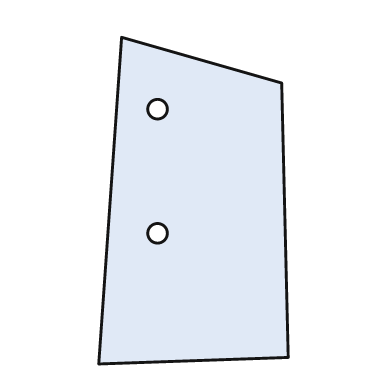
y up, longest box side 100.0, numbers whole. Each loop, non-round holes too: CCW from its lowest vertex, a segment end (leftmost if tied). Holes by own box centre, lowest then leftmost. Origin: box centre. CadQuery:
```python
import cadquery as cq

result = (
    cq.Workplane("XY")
    .moveTo(-29.0, -50.0)
    .lineTo(29.0, -48.0)
    .lineTo(27.0, 36.0)
    .lineTo(-22.0, 50.0)
    .close()
    .moveTo(-11.0, -10.0)
    .circle(3.0)
    .moveTo(-11.0, 28.0)
    .circle(3.0)
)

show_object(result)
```